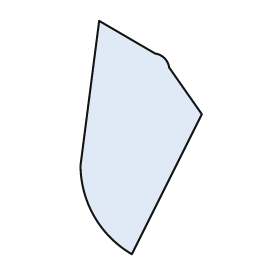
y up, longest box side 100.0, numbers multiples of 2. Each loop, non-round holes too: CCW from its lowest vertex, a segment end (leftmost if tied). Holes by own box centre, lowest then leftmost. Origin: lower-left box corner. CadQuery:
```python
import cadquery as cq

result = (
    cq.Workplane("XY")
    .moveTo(22.0, 0.0)
    .lineTo(52.0, 60.0)
    .lineTo(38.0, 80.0)
    .threePointArc((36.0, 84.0), (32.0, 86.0))
    .lineTo(8.0, 100.0)
    .lineTo(0.0, 38.0)
    .threePointArc((6.0, 16.0), (22.0, 0.0))
    .close()
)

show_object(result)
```